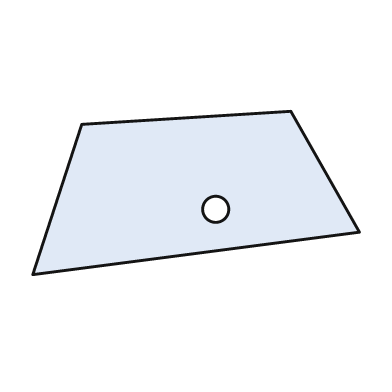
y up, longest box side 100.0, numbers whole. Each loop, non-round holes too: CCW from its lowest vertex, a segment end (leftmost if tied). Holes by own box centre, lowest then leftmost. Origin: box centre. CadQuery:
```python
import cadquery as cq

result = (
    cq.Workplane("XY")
    .moveTo(-50.0, -25.0)
    .lineTo(50.0, -12.0)
    .lineTo(29.0, 25.0)
    .lineTo(-35.0, 21.0)
    .close()
    .moveTo(6.0, -5.0)
    .circle(4.0)
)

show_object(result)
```